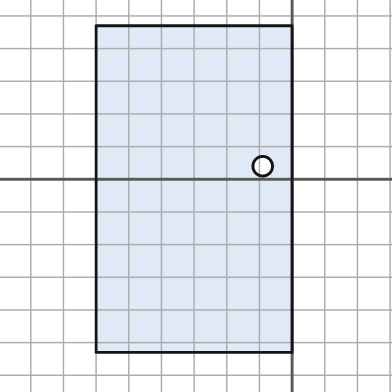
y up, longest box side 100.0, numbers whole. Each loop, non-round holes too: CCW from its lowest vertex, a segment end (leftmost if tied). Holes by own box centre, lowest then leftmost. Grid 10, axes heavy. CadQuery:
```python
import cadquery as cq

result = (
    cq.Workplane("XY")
    .moveTo(-60.0, -53.0)
    .lineTo(0.0, -53.0)
    .lineTo(0.0, 47.0)
    .lineTo(-60.0, 47.0)
    .close()
    .moveTo(-9.0, 4.0)
    .circle(3.0)
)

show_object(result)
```